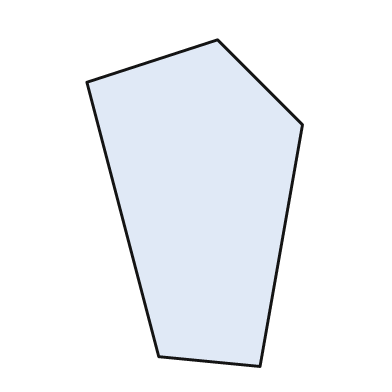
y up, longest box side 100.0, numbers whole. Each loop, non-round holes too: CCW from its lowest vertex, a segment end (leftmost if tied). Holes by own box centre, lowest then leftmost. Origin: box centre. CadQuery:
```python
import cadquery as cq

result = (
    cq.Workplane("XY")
    .moveTo(20.0, -50.0)
    .lineTo(33.0, 24.0)
    .lineTo(7.0, 50.0)
    .lineTo(-33.0, 37.0)
    .lineTo(-11.0, -47.0)
    .close()
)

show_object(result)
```